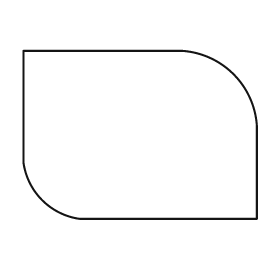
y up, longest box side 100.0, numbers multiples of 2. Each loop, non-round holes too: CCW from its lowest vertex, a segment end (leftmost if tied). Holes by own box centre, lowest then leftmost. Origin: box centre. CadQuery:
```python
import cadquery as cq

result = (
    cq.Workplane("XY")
    .moveTo(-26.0, -36.0)
    .lineTo(50.0, -36.0)
    .lineTo(50.0, 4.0)
    .threePointArc((40.0, 26.0), (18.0, 36.0))
    .lineTo(-50.0, 36.0)
    .lineTo(-50.0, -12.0)
    .threePointArc((-42.0, -28.0), (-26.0, -36.0))
    .close()
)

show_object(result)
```